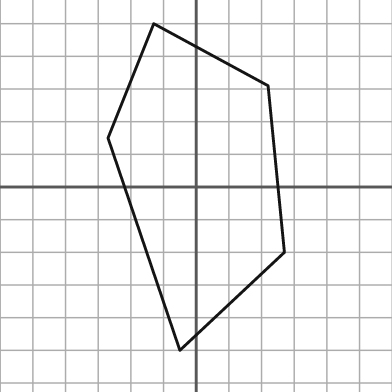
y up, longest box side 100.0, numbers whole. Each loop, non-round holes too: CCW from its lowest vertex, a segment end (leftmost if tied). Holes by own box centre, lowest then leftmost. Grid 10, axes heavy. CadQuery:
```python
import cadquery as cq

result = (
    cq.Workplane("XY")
    .moveTo(-5.0, -50.0)
    .lineTo(27.0, -20.0)
    .lineTo(22.0, 31.0)
    .lineTo(-13.0, 50.0)
    .lineTo(-27.0, 15.0)
    .close()
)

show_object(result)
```